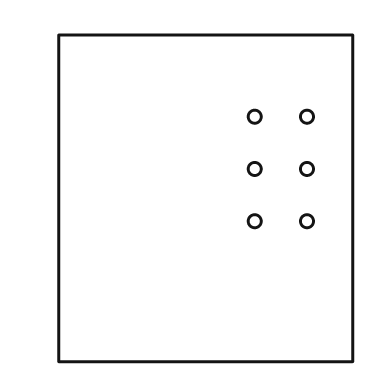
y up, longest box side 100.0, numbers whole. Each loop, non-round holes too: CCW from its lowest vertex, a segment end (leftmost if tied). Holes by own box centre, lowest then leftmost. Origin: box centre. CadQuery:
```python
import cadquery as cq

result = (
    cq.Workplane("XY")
    .moveTo(-45.0, -50.0)
    .lineTo(45.0, -50.0)
    .lineTo(45.0, 50.0)
    .lineTo(-45.0, 50.0)
    .close()
    .moveTo(15.0, -7.0)
    .circle(2.0)
    .moveTo(31.0, -7.0)
    .circle(2.0)
    .moveTo(15.0, 9.0)
    .circle(2.0)
    .moveTo(31.0, 9.0)
    .circle(2.0)
    .moveTo(15.0, 25.0)
    .circle(2.0)
    .moveTo(31.0, 25.0)
    .circle(2.0)
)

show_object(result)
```